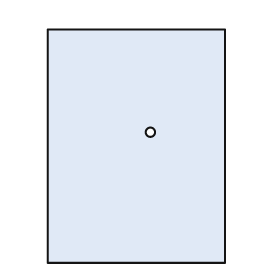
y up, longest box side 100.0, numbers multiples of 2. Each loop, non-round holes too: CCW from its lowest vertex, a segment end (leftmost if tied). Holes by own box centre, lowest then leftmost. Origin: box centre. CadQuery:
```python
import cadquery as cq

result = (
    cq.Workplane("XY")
    .moveTo(-38.0, -50.0)
    .lineTo(38.0, -50.0)
    .lineTo(38.0, 50.0)
    .lineTo(-38.0, 50.0)
    .close()
    .moveTo(6.0, 6.0)
    .circle(2.0)
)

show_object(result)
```